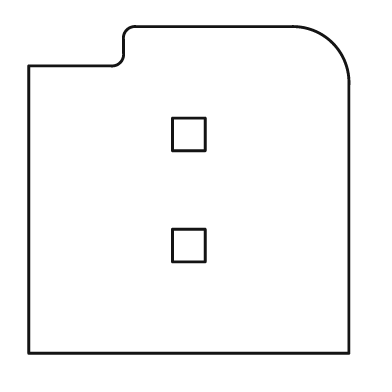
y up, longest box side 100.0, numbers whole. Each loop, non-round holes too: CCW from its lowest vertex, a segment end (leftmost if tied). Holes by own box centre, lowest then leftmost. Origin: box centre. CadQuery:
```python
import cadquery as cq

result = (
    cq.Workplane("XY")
    .moveTo(-49.0, -50.0)
    .lineTo(49.0, -50.0)
    .lineTo(49.0, 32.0)
    .threePointArc((44.0, 45.0), (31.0, 50.0))
    .lineTo(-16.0, 50.0)
    .threePointArc((-19.0, 49.0), (-20.0, 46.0))
    .lineTo(-20.0, 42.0)
    .threePointArc((-21.0, 39.0), (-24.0, 38.0))
    .lineTo(-49.0, 38.0)
    .close()
    .moveTo(-5.0, -22.0)
    .lineTo(5.0, -22.0)
    .lineTo(5.0, -12.0)
    .lineTo(-5.0, -12.0)
    .close()
    .moveTo(-5.0, 12.0)
    .lineTo(5.0, 12.0)
    .lineTo(5.0, 22.0)
    .lineTo(-5.0, 22.0)
    .close()
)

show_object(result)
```